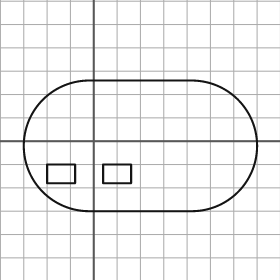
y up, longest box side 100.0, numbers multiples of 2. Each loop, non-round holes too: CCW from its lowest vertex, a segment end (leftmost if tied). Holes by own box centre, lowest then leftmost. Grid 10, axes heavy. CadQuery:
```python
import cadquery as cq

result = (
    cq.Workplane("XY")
    .moveTo(-2.0, -30.0)
    .lineTo(42.0, -30.0)
    .threePointArc((70.0, -2.0), (42.0, 26.0))
    .lineTo(-2.0, 26.0)
    .threePointArc((-30.0, -2.0), (-2.0, -30.0))
    .close()
    .moveTo(-20.0, -18.0)
    .lineTo(-8.0, -18.0)
    .lineTo(-8.0, -10.0)
    .lineTo(-20.0, -10.0)
    .close()
    .moveTo(4.0, -18.0)
    .lineTo(16.0, -18.0)
    .lineTo(16.0, -10.0)
    .lineTo(4.0, -10.0)
    .close()
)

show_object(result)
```